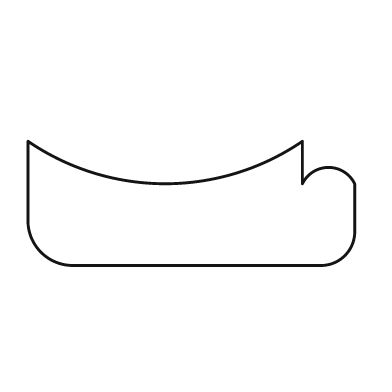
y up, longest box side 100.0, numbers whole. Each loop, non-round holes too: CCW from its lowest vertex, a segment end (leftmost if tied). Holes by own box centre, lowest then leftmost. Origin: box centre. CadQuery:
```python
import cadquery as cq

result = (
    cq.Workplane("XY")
    .moveTo(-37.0, -19.0)
    .lineTo(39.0, -19.0)
    .threePointArc((47.0, -16.0), (50.0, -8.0))
    .lineTo(50.0, 6.0)
    .threePointArc((42.0, 11.0), (34.0, 6.0))
    .lineTo(34.0, 19.0)
    .threePointArc((-8.0, 6.0), (-50.0, 19.0))
    .lineTo(-50.0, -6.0)
    .threePointArc((-46.0, -15.0), (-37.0, -19.0))
    .close()
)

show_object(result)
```